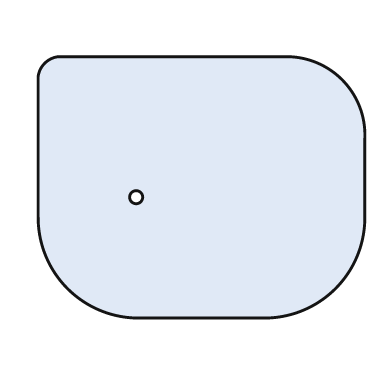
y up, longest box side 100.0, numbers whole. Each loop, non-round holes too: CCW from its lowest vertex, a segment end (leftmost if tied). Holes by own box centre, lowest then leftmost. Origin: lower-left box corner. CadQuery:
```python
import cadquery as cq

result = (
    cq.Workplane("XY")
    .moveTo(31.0, 0.0)
    .lineTo(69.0, 0.0)
    .threePointArc((91.0, 9.0), (100.0, 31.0))
    .lineTo(100.0, 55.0)
    .threePointArc((93.0, 73.0), (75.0, 80.0))
    .lineTo(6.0, 80.0)
    .threePointArc((2.0, 78.0), (0.0, 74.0))
    .lineTo(0.0, 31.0)
    .threePointArc((9.0, 9.0), (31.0, 0.0))
    .close()
    .moveTo(30.0, 37.0)
    .circle(2.0)
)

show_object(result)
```